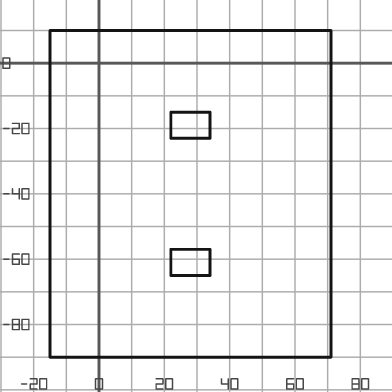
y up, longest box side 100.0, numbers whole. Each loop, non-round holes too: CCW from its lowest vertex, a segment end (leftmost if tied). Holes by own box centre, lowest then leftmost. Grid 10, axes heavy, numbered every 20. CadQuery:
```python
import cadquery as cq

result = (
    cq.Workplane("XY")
    .moveTo(-15.0, -90.0)
    .lineTo(71.0, -90.0)
    .lineTo(71.0, 10.0)
    .lineTo(-15.0, 10.0)
    .close()
    .moveTo(22.0, -65.0)
    .lineTo(34.0, -65.0)
    .lineTo(34.0, -57.0)
    .lineTo(22.0, -57.0)
    .close()
    .moveTo(22.0, -23.0)
    .lineTo(34.0, -23.0)
    .lineTo(34.0, -15.0)
    .lineTo(22.0, -15.0)
    .close()
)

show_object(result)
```